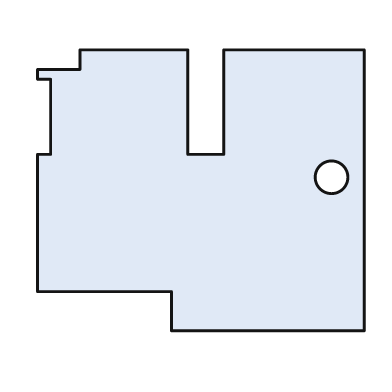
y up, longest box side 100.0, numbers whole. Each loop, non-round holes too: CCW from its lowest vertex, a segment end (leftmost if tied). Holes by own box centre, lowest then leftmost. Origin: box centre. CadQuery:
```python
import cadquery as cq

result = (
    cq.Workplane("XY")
    .moveTo(-9.0, -43.0)
    .lineTo(50.0, -43.0)
    .lineTo(50.0, 43.0)
    .lineTo(7.0, 43.0)
    .lineTo(7.0, 11.0)
    .lineTo(-4.0, 11.0)
    .lineTo(-4.0, 43.0)
    .lineTo(-37.0, 43.0)
    .lineTo(-37.0, 37.0)
    .lineTo(-50.0, 37.0)
    .lineTo(-50.0, 34.0)
    .lineTo(-46.0, 34.0)
    .lineTo(-46.0, 11.0)
    .lineTo(-50.0, 11.0)
    .lineTo(-50.0, -31.0)
    .lineTo(-9.0, -31.0)
    .close()
    .moveTo(40.0, 4.0)
    .circle(5.0)
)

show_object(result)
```